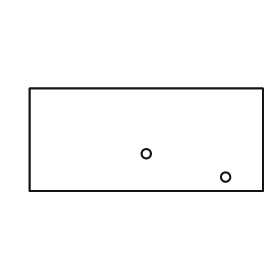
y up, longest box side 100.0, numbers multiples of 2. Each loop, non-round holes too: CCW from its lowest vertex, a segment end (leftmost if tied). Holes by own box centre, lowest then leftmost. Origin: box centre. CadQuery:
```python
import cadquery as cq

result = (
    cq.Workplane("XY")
    .moveTo(-50.0, -22.0)
    .lineTo(50.0, -22.0)
    .lineTo(50.0, 22.0)
    .lineTo(-50.0, 22.0)
    .close()
    .moveTo(34.0, -16.0)
    .circle(2.0)
    .moveTo(0.0, -6.0)
    .circle(2.0)
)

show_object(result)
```